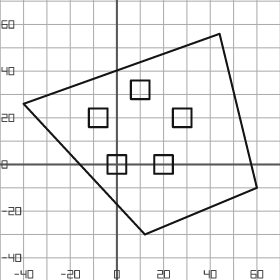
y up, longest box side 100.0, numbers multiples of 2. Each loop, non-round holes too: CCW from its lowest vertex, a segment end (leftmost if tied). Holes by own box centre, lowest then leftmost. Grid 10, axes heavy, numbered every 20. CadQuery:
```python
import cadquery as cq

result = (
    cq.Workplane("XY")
    .moveTo(12.0, -30.0)
    .lineTo(60.0, -10.0)
    .lineTo(44.0, 56.0)
    .lineTo(-40.0, 26.0)
    .close()
    .moveTo(-4.0, -4.0)
    .lineTo(4.0, -4.0)
    .lineTo(4.0, 4.0)
    .lineTo(-4.0, 4.0)
    .close()
    .moveTo(16.0, -4.0)
    .lineTo(24.0, -4.0)
    .lineTo(24.0, 4.0)
    .lineTo(16.0, 4.0)
    .close()
    .moveTo(-12.0, 16.0)
    .lineTo(-4.0, 16.0)
    .lineTo(-4.0, 24.0)
    .lineTo(-12.0, 24.0)
    .close()
    .moveTo(24.0, 16.0)
    .lineTo(32.0, 16.0)
    .lineTo(32.0, 24.0)
    .lineTo(24.0, 24.0)
    .close()
    .moveTo(6.0, 28.0)
    .lineTo(14.0, 28.0)
    .lineTo(14.0, 36.0)
    .lineTo(6.0, 36.0)
    .close()
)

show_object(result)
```